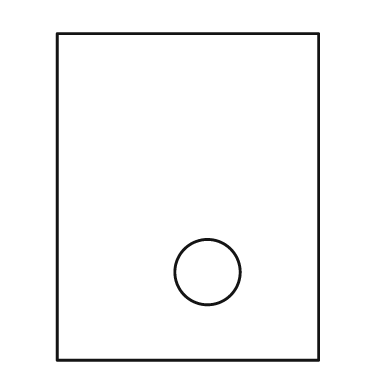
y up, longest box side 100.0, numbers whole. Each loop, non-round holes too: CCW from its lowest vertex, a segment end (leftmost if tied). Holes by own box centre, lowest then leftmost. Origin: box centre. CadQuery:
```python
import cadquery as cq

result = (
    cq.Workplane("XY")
    .moveTo(-40.0, -50.0)
    .lineTo(40.0, -50.0)
    .lineTo(40.0, 50.0)
    .lineTo(-40.0, 50.0)
    .close()
    .moveTo(6.0, -23.0)
    .circle(10.0)
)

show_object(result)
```